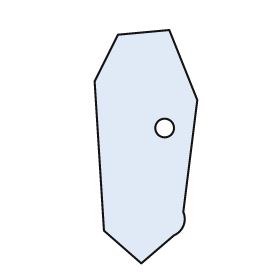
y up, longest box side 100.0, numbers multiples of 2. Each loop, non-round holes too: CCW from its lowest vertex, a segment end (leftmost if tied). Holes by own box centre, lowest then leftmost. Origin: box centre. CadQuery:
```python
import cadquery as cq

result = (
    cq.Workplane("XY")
    .moveTo(-2.0, -50.0)
    .lineTo(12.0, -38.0)
    .threePointArc((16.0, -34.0), (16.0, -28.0))
    .lineTo(22.0, 20.0)
    .lineTo(10.0, 50.0)
    .lineTo(-12.0, 48.0)
    .lineTo(-22.0, 28.0)
    .lineTo(-18.0, -36.0)
    .close()
    .moveTo(8.0, 8.0)
    .circle(4.0)
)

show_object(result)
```